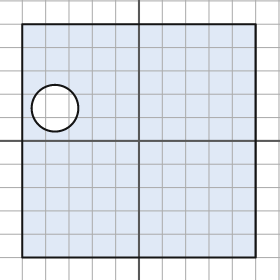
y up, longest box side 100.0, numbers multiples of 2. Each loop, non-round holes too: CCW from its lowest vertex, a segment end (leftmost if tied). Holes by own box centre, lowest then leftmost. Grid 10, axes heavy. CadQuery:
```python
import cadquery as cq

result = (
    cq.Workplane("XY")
    .moveTo(-50.0, -50.0)
    .lineTo(50.0, -50.0)
    .lineTo(50.0, 50.0)
    .lineTo(-50.0, 50.0)
    .close()
    .moveTo(-36.0, 14.0)
    .circle(10.0)
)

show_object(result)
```